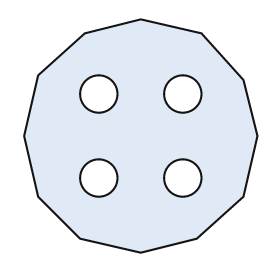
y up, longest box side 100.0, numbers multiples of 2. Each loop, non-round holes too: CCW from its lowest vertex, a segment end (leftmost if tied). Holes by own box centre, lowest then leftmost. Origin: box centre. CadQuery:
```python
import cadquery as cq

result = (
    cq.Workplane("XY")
    .moveTo(0.0, -50.0)
    .lineTo(24.0, -44.0)
    .lineTo(44.0, -26.0)
    .lineTo(50.0, 0.0)
    .lineTo(44.0, 24.0)
    .lineTo(26.0, 44.0)
    .lineTo(0.0, 50.0)
    .lineTo(-24.0, 44.0)
    .lineTo(-44.0, 26.0)
    .lineTo(-50.0, 0.0)
    .lineTo(-44.0, -26.0)
    .lineTo(-26.0, -44.0)
    .close()
    .moveTo(-18.0, -18.0)
    .circle(8.0)
    .moveTo(18.0, -18.0)
    .circle(8.0)
    .moveTo(-18.0, 18.0)
    .circle(8.0)
    .moveTo(18.0, 18.0)
    .circle(8.0)
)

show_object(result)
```